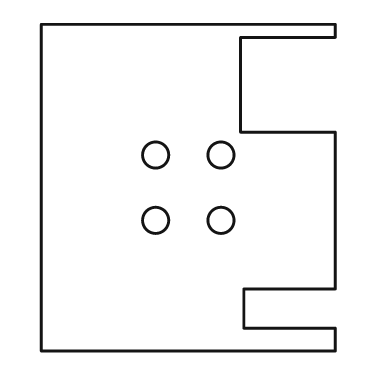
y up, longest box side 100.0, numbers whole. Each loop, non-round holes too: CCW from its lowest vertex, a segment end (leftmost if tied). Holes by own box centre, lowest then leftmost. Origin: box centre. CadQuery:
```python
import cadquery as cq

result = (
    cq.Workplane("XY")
    .moveTo(-45.0, -50.0)
    .lineTo(45.0, -50.0)
    .lineTo(45.0, -43.0)
    .lineTo(17.0, -43.0)
    .lineTo(17.0, -31.0)
    .lineTo(45.0, -31.0)
    .lineTo(45.0, 17.0)
    .lineTo(16.0, 17.0)
    .lineTo(16.0, 46.0)
    .lineTo(45.0, 46.0)
    .lineTo(45.0, 50.0)
    .lineTo(-45.0, 50.0)
    .close()
    .moveTo(-10.0, -10.0)
    .circle(4.0)
    .moveTo(10.0, -10.0)
    .circle(4.0)
    .moveTo(-10.0, 10.0)
    .circle(4.0)
    .moveTo(10.0, 10.0)
    .circle(4.0)
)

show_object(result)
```